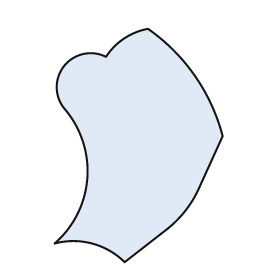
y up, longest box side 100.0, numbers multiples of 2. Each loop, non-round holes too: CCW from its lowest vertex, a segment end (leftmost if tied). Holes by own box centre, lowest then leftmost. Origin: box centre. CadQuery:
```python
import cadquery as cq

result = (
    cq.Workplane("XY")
    .moveTo(-6.0, -50.0)
    .lineTo(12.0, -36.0)
    .threePointArc((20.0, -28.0), (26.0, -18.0))
    .lineTo(36.0, 4.0)
    .threePointArc((24.0, 30.0), (4.0, 50.0))
    .threePointArc((-6.0, 46.0), (-14.0, 38.0))
    .threePointArc((-32.0, 34.0), (-32.0, 16.0))
    .threePointArc((-22.0, -14.0), (-36.0, -42.0))
    .threePointArc((-20.0, -42.0), (-6.0, -50.0))
    .close()
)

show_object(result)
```